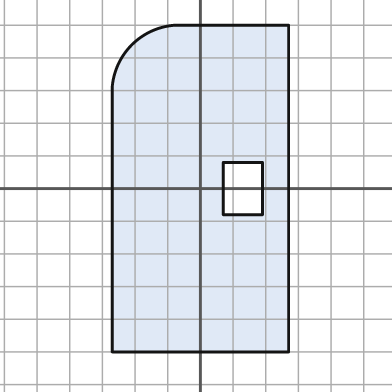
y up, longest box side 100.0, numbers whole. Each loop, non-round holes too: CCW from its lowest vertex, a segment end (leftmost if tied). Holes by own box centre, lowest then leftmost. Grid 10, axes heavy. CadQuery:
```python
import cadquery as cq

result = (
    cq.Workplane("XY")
    .moveTo(-27.0, -50.0)
    .lineTo(27.0, -50.0)
    .lineTo(27.0, 50.0)
    .lineTo(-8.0, 50.0)
    .threePointArc((-21.0, 44.0), (-27.0, 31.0))
    .close()
    .moveTo(7.0, -8.0)
    .lineTo(19.0, -8.0)
    .lineTo(19.0, 8.0)
    .lineTo(7.0, 8.0)
    .close()
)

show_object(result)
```